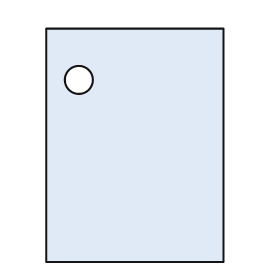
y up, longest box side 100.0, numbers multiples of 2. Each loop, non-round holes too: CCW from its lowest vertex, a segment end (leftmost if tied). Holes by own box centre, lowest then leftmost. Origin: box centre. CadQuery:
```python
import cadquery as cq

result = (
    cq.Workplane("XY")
    .moveTo(-38.0, -50.0)
    .lineTo(38.0, -50.0)
    .lineTo(38.0, 50.0)
    .lineTo(-38.0, 50.0)
    .close()
    .moveTo(-24.0, 28.0)
    .circle(6.0)
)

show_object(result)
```